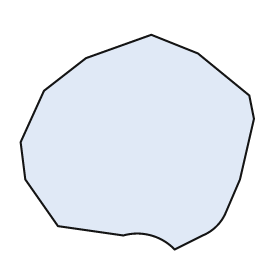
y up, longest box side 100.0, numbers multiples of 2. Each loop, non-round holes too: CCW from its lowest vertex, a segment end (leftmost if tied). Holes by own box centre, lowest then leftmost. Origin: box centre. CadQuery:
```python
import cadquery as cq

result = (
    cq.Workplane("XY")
    .moveTo(16.0, -46.0)
    .lineTo(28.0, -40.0)
    .threePointArc((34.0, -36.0), (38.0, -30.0))
    .lineTo(44.0, -16.0)
    .lineTo(50.0, 10.0)
    .lineTo(48.0, 20.0)
    .lineTo(26.0, 38.0)
    .lineTo(6.0, 46.0)
    .lineTo(-22.0, 36.0)
    .lineTo(-40.0, 22.0)
    .lineTo(-50.0, 0.0)
    .lineTo(-48.0, -16.0)
    .lineTo(-34.0, -36.0)
    .lineTo(-6.0, -40.0)
    .threePointArc((6.0, -40.0), (16.0, -46.0))
    .close()
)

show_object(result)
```